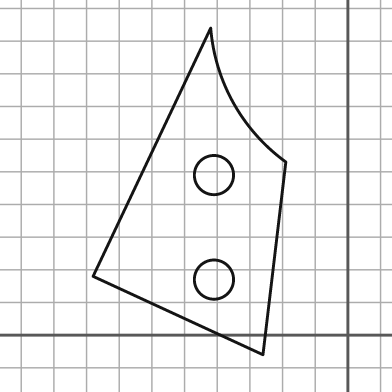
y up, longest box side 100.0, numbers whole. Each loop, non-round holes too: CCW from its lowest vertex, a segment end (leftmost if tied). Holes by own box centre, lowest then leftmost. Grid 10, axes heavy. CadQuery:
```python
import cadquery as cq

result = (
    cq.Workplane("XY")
    .moveTo(-26.0, -6.0)
    .lineTo(-19.0, 53.0)
    .threePointArc((-35.0, 71.0), (-42.0, 94.0))
    .lineTo(-78.0, 18.0)
    .close()
    .moveTo(-41.0, 17.0)
    .circle(6.0)
    .moveTo(-41.0, 49.0)
    .circle(6.0)
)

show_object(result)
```